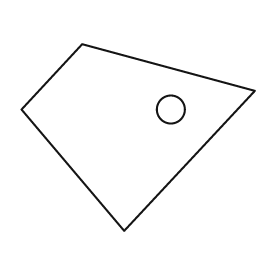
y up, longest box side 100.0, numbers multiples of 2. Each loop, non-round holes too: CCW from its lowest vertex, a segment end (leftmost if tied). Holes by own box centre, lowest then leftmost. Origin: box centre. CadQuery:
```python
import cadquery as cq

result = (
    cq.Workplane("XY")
    .moveTo(-6.0, -40.0)
    .lineTo(50.0, 20.0)
    .lineTo(-24.0, 40.0)
    .lineTo(-50.0, 12.0)
    .close()
    .moveTo(14.0, 12.0)
    .circle(6.0)
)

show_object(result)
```